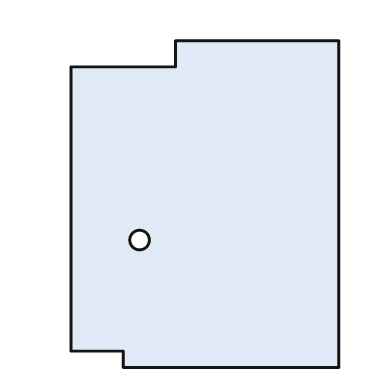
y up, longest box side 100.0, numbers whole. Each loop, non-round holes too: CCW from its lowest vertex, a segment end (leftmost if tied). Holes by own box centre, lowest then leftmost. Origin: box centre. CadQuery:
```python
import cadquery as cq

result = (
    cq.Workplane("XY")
    .moveTo(-25.0, -50.0)
    .lineTo(41.0, -50.0)
    .lineTo(41.0, 50.0)
    .lineTo(-9.0, 50.0)
    .lineTo(-9.0, 42.0)
    .lineTo(-41.0, 42.0)
    .lineTo(-41.0, -45.0)
    .lineTo(-25.0, -45.0)
    .close()
    .moveTo(-20.0, -11.0)
    .circle(3.0)
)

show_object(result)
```